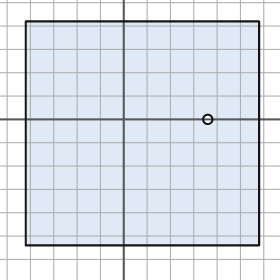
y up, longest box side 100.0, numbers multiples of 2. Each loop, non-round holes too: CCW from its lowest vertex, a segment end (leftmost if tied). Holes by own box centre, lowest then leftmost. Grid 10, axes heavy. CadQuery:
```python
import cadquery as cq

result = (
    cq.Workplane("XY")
    .moveTo(-42.0, -54.0)
    .lineTo(58.0, -54.0)
    .lineTo(58.0, 42.0)
    .lineTo(-42.0, 42.0)
    .close()
    .moveTo(36.0, 0.0)
    .circle(2.0)
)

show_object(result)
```